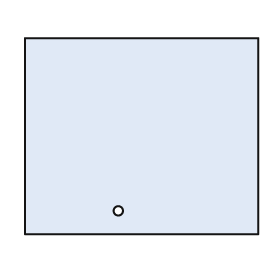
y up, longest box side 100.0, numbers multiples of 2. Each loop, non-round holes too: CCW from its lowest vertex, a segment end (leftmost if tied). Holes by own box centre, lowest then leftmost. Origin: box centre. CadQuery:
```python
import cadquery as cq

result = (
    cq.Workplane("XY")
    .moveTo(-50.0, -42.0)
    .lineTo(50.0, -42.0)
    .lineTo(50.0, 42.0)
    .lineTo(-50.0, 42.0)
    .close()
    .moveTo(-10.0, -32.0)
    .circle(2.0)
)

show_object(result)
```